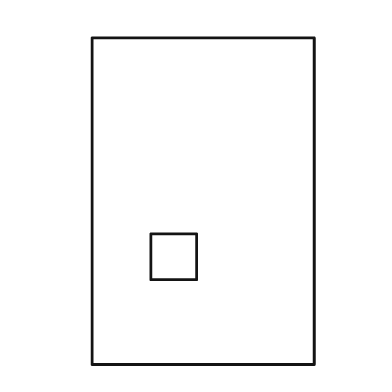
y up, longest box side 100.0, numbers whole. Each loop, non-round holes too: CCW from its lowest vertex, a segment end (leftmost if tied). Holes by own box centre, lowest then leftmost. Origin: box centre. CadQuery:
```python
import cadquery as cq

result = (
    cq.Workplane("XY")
    .moveTo(-34.0, -50.0)
    .lineTo(34.0, -50.0)
    .lineTo(34.0, 50.0)
    .lineTo(-34.0, 50.0)
    .close()
    .moveTo(-16.0, -24.0)
    .lineTo(-2.0, -24.0)
    .lineTo(-2.0, -10.0)
    .lineTo(-16.0, -10.0)
    .close()
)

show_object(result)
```